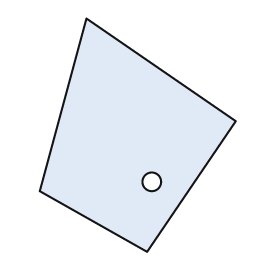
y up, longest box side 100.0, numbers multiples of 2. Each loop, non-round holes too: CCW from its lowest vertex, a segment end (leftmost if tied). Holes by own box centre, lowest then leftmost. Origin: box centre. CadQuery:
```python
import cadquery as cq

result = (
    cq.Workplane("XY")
    .moveTo(4.0, -50.0)
    .lineTo(42.0, 6.0)
    .lineTo(-22.0, 50.0)
    .lineTo(-42.0, -24.0)
    .close()
    .moveTo(6.0, -20.0)
    .circle(4.0)
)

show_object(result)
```